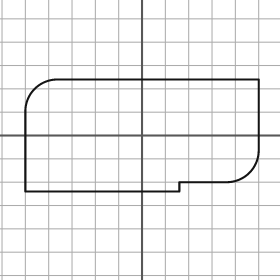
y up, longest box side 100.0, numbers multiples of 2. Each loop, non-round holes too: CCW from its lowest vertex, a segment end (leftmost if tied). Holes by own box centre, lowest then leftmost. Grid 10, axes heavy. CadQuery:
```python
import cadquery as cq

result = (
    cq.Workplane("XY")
    .moveTo(-50.0, -24.0)
    .lineTo(16.0, -24.0)
    .lineTo(16.0, -20.0)
    .lineTo(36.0, -20.0)
    .threePointArc((46.0, -16.0), (50.0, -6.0))
    .lineTo(50.0, 24.0)
    .lineTo(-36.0, 24.0)
    .threePointArc((-46.0, 20.0), (-50.0, 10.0))
    .close()
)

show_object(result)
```